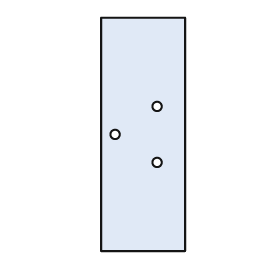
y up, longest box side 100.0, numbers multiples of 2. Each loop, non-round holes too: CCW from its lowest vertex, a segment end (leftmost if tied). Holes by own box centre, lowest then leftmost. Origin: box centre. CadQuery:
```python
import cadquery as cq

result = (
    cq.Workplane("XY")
    .moveTo(-18.0, -50.0)
    .lineTo(18.0, -50.0)
    .lineTo(18.0, 50.0)
    .lineTo(-18.0, 50.0)
    .close()
    .moveTo(6.0, -12.0)
    .circle(2.0)
    .moveTo(-12.0, 0.0)
    .circle(2.0)
    .moveTo(6.0, 12.0)
    .circle(2.0)
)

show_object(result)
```